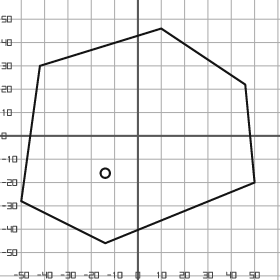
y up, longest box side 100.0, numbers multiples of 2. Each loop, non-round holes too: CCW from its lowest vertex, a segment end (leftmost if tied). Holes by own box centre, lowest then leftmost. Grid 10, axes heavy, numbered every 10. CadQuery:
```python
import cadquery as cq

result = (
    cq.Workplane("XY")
    .moveTo(-14.0, -46.0)
    .lineTo(50.0, -20.0)
    .lineTo(46.0, 22.0)
    .lineTo(10.0, 46.0)
    .lineTo(-42.0, 30.0)
    .lineTo(-50.0, -28.0)
    .close()
    .moveTo(-14.0, -16.0)
    .circle(2.0)
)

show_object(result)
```